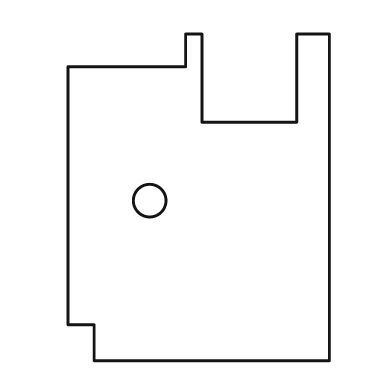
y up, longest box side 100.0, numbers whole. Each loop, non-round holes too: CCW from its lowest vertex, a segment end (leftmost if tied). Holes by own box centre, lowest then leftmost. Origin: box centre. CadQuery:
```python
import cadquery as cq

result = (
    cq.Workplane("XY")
    .moveTo(-32.0, -50.0)
    .lineTo(40.0, -50.0)
    .lineTo(40.0, 50.0)
    .lineTo(30.0, 50.0)
    .lineTo(30.0, 23.0)
    .lineTo(1.0, 23.0)
    .lineTo(1.0, 50.0)
    .lineTo(-4.0, 50.0)
    .lineTo(-4.0, 40.0)
    .lineTo(-40.0, 40.0)
    .lineTo(-40.0, -39.0)
    .lineTo(-32.0, -39.0)
    .close()
    .moveTo(-15.0, -1.0)
    .circle(5.0)
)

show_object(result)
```